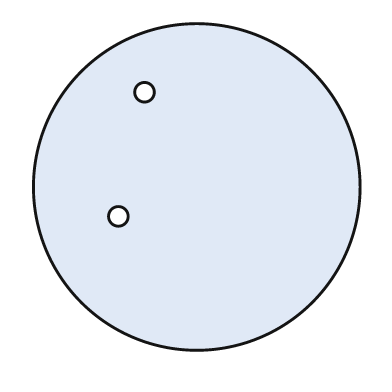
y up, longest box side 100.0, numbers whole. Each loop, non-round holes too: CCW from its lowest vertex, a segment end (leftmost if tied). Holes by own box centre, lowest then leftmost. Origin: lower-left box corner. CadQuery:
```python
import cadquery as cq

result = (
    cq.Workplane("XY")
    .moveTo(50.0, 50.0)
    .circle(50.0)
    .moveTo(26.0, 41.0)
    .circle(3.0)
    .moveTo(34.0, 79.0)
    .circle(3.0)
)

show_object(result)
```